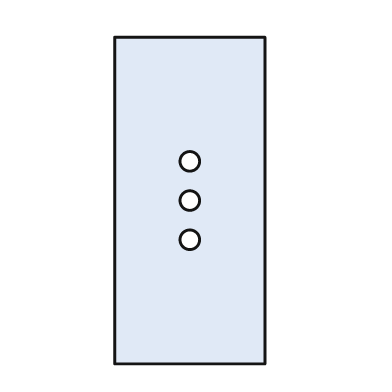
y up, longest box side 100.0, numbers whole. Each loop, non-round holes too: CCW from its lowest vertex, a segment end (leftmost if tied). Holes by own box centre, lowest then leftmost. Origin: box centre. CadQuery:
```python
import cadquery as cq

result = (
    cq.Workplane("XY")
    .moveTo(-23.0, -50.0)
    .lineTo(23.0, -50.0)
    .lineTo(23.0, 50.0)
    .lineTo(-23.0, 50.0)
    .close()
    .moveTo(0.0, -12.0)
    .circle(3.0)
    .moveTo(0.0, 0.0)
    .circle(3.0)
    .moveTo(0.0, 12.0)
    .circle(3.0)
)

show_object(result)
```